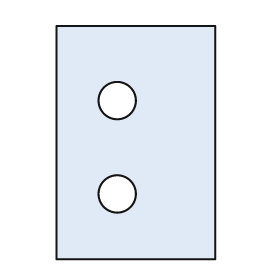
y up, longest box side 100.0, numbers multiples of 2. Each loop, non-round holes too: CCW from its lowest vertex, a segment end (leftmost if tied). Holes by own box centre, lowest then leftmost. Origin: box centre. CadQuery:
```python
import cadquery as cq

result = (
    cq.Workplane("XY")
    .moveTo(-34.0, -50.0)
    .lineTo(34.0, -50.0)
    .lineTo(34.0, 50.0)
    .lineTo(-34.0, 50.0)
    .close()
    .moveTo(-8.0, -22.0)
    .circle(8.0)
    .moveTo(-8.0, 18.0)
    .circle(8.0)
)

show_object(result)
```